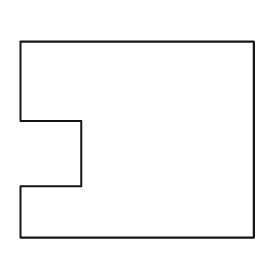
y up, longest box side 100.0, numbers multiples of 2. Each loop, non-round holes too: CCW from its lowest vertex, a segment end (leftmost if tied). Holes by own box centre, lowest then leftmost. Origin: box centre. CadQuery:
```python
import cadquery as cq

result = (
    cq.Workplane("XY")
    .moveTo(-50.0, -42.0)
    .lineTo(50.0, -42.0)
    .lineTo(50.0, 42.0)
    .lineTo(-50.0, 42.0)
    .lineTo(-50.0, 8.0)
    .lineTo(-24.0, 8.0)
    .lineTo(-24.0, -20.0)
    .lineTo(-50.0, -20.0)
    .close()
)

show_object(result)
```